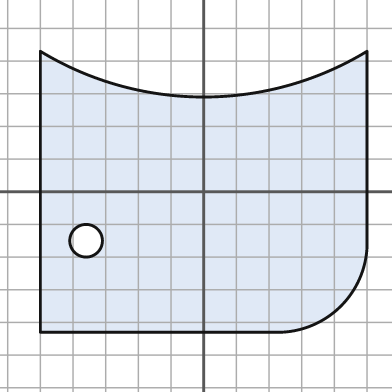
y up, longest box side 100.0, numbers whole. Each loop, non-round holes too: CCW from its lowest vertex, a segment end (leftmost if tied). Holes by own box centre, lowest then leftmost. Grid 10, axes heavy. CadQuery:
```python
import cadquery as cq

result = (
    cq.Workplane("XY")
    .moveTo(-50.0, -43.0)
    .lineTo(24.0, -43.0)
    .threePointArc((42.0, -35.0), (50.0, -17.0))
    .lineTo(50.0, 43.0)
    .threePointArc((0.0, 29.0), (-50.0, 43.0))
    .close()
    .moveTo(-36.0, -15.0)
    .circle(5.0)
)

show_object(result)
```